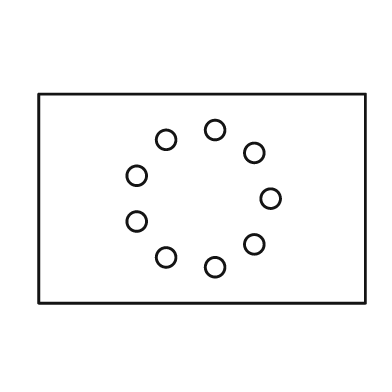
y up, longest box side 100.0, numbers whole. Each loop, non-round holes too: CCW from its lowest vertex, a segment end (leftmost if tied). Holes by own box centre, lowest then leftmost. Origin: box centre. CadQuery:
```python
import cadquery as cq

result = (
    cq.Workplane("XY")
    .moveTo(-50.0, -32.0)
    .lineTo(50.0, -32.0)
    .lineTo(50.0, 32.0)
    .lineTo(-50.0, 32.0)
    .close()
    .moveTo(4.0, -21.0)
    .circle(3.0)
    .moveTo(-11.0, -18.0)
    .circle(3.0)
    .moveTo(16.0, -14.0)
    .circle(3.0)
    .moveTo(-20.0, -7.0)
    .circle(3.0)
    .moveTo(21.0, 0.0)
    .circle(3.0)
    .moveTo(-20.0, 7.0)
    .circle(3.0)
    .moveTo(16.0, 14.0)
    .circle(3.0)
    .moveTo(-11.0, 18.0)
    .circle(3.0)
    .moveTo(4.0, 21.0)
    .circle(3.0)
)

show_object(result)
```